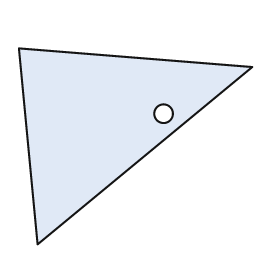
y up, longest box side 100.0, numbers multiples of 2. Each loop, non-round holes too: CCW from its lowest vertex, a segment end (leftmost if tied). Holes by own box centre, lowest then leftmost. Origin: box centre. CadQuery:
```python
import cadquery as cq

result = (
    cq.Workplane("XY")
    .moveTo(-42.0, -42.0)
    .lineTo(50.0, 34.0)
    .lineTo(-50.0, 42.0)
    .close()
    .moveTo(12.0, 14.0)
    .circle(4.0)
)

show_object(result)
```